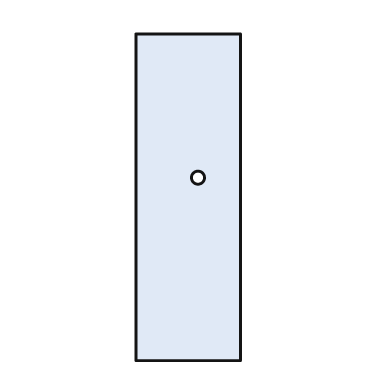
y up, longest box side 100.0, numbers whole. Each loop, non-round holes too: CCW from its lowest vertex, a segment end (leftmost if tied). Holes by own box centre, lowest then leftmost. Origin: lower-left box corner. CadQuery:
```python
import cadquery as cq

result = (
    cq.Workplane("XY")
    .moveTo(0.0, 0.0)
    .lineTo(32.0, 0.0)
    .lineTo(32.0, 100.0)
    .lineTo(0.0, 100.0)
    .close()
    .moveTo(19.0, 56.0)
    .circle(2.0)
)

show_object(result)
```